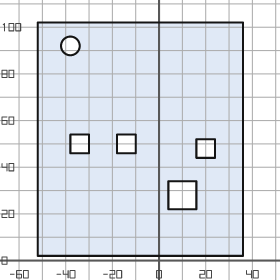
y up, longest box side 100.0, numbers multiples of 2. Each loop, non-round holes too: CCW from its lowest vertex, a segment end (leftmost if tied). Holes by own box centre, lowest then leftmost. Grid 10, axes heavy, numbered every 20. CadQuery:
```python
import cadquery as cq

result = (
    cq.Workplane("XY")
    .moveTo(-52.0, 2.0)
    .lineTo(36.0, 2.0)
    .lineTo(36.0, 102.0)
    .lineTo(-52.0, 102.0)
    .close()
    .moveTo(4.0, 22.0)
    .lineTo(16.0, 22.0)
    .lineTo(16.0, 34.0)
    .lineTo(4.0, 34.0)
    .close()
    .moveTo(16.0, 44.0)
    .lineTo(24.0, 44.0)
    .lineTo(24.0, 52.0)
    .lineTo(16.0, 52.0)
    .close()
    .moveTo(-38.0, 46.0)
    .lineTo(-30.0, 46.0)
    .lineTo(-30.0, 54.0)
    .lineTo(-38.0, 54.0)
    .close()
    .moveTo(-18.0, 46.0)
    .lineTo(-10.0, 46.0)
    .lineTo(-10.0, 54.0)
    .lineTo(-18.0, 54.0)
    .close()
    .moveTo(-38.0, 92.0)
    .circle(4.0)
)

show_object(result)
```